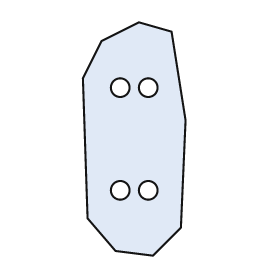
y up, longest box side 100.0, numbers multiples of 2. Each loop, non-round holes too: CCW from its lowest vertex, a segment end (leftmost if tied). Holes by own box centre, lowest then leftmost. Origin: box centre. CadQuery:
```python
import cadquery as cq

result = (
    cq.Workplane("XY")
    .moveTo(8.0, -50.0)
    .lineTo(20.0, -38.0)
    .lineTo(22.0, 8.0)
    .lineTo(16.0, 46.0)
    .lineTo(2.0, 50.0)
    .lineTo(-14.0, 42.0)
    .lineTo(-22.0, 26.0)
    .lineTo(-20.0, -34.0)
    .lineTo(-8.0, -48.0)
    .close()
    .moveTo(-6.0, -22.0)
    .circle(4.0)
    .moveTo(6.0, -22.0)
    .circle(4.0)
    .moveTo(-6.0, 22.0)
    .circle(4.0)
    .moveTo(6.0, 22.0)
    .circle(4.0)
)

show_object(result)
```